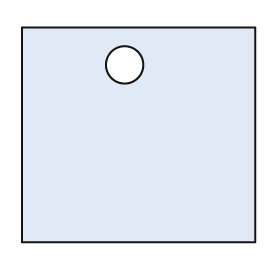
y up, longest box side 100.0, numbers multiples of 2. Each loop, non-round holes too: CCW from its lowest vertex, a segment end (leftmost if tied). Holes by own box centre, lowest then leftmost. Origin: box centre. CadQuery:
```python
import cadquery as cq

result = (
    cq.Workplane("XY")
    .moveTo(-50.0, -46.0)
    .lineTo(50.0, -46.0)
    .lineTo(50.0, 46.0)
    .lineTo(-50.0, 46.0)
    .close()
    .moveTo(-6.0, 30.0)
    .circle(8.0)
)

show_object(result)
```